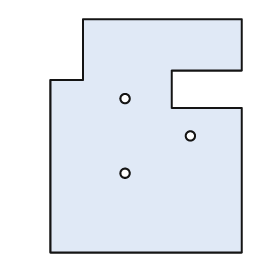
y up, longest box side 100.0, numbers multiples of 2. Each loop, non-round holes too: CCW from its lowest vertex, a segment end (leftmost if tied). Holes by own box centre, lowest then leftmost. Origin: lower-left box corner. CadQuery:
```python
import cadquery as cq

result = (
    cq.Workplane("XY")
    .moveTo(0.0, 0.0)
    .lineTo(82.0, 0.0)
    .lineTo(82.0, 62.0)
    .lineTo(52.0, 62.0)
    .lineTo(52.0, 78.0)
    .lineTo(82.0, 78.0)
    .lineTo(82.0, 100.0)
    .lineTo(14.0, 100.0)
    .lineTo(14.0, 74.0)
    .lineTo(0.0, 74.0)
    .close()
    .moveTo(32.0, 34.0)
    .circle(2.0)
    .moveTo(60.0, 50.0)
    .circle(2.0)
    .moveTo(32.0, 66.0)
    .circle(2.0)
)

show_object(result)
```